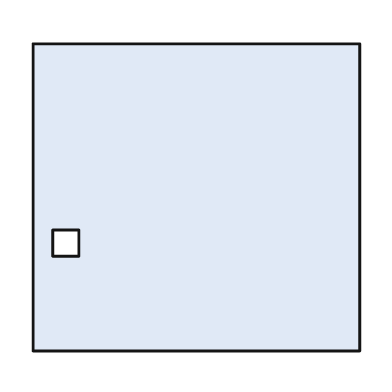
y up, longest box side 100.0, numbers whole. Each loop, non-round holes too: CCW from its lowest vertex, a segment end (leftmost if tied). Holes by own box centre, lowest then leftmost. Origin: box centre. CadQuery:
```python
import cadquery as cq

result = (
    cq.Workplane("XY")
    .moveTo(-50.0, -47.0)
    .lineTo(50.0, -47.0)
    .lineTo(50.0, 47.0)
    .lineTo(-50.0, 47.0)
    .close()
    .moveTo(-44.0, -18.0)
    .lineTo(-36.0, -18.0)
    .lineTo(-36.0, -10.0)
    .lineTo(-44.0, -10.0)
    .close()
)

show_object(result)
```